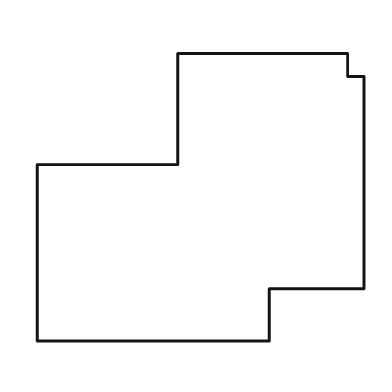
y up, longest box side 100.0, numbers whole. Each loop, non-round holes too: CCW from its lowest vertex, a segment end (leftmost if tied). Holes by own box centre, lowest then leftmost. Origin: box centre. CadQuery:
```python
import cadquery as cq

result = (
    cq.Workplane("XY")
    .moveTo(-50.0, -44.0)
    .lineTo(21.0, -44.0)
    .lineTo(21.0, -28.0)
    .lineTo(50.0, -28.0)
    .lineTo(50.0, 37.0)
    .lineTo(45.0, 37.0)
    .lineTo(45.0, 44.0)
    .lineTo(-7.0, 44.0)
    .lineTo(-7.0, 10.0)
    .lineTo(-50.0, 10.0)
    .close()
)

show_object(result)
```